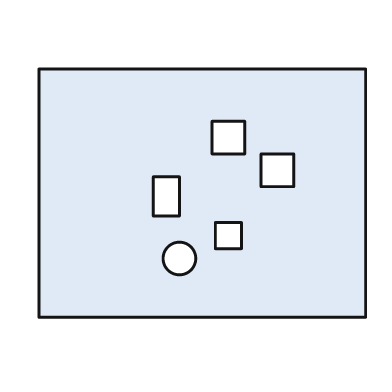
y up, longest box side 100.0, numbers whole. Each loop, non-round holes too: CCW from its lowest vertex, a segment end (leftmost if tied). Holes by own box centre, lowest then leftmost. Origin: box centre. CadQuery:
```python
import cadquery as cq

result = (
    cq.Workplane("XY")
    .moveTo(-50.0, -38.0)
    .lineTo(50.0, -38.0)
    .lineTo(50.0, 38.0)
    .lineTo(-50.0, 38.0)
    .close()
    .moveTo(-7.0, -20.0)
    .circle(5.0)
    .moveTo(4.0, -17.0)
    .lineTo(12.0, -17.0)
    .lineTo(12.0, -9.0)
    .lineTo(4.0, -9.0)
    .close()
    .moveTo(-15.0, -7.0)
    .lineTo(-7.0, -7.0)
    .lineTo(-7.0, 5.0)
    .lineTo(-15.0, 5.0)
    .close()
    .moveTo(18.0, 2.0)
    .lineTo(28.0, 2.0)
    .lineTo(28.0, 12.0)
    .lineTo(18.0, 12.0)
    .close()
    .moveTo(3.0, 12.0)
    .lineTo(13.0, 12.0)
    .lineTo(13.0, 22.0)
    .lineTo(3.0, 22.0)
    .close()
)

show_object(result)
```